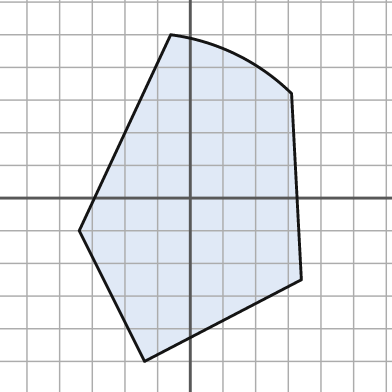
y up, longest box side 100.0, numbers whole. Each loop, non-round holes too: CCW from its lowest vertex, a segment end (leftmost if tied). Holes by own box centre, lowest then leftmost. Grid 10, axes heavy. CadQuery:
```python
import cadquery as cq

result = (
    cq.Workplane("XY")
    .moveTo(-14.0, -50.0)
    .lineTo(34.0, -25.0)
    .lineTo(31.0, 32.0)
    .threePointArc((14.0, 44.0), (-6.0, 50.0))
    .lineTo(-34.0, -10.0)
    .close()
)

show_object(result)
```